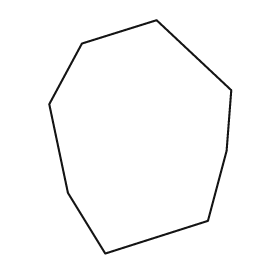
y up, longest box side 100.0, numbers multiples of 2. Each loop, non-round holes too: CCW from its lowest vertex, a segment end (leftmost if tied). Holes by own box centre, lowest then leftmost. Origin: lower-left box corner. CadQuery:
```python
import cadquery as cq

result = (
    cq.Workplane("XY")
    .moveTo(24.0, 0.0)
    .lineTo(68.0, 14.0)
    .lineTo(76.0, 44.0)
    .lineTo(78.0, 70.0)
    .lineTo(46.0, 100.0)
    .lineTo(14.0, 90.0)
    .lineTo(0.0, 64.0)
    .lineTo(8.0, 26.0)
    .close()
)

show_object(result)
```